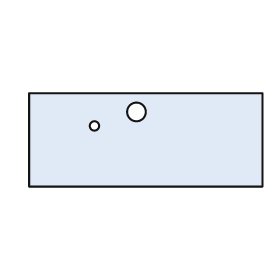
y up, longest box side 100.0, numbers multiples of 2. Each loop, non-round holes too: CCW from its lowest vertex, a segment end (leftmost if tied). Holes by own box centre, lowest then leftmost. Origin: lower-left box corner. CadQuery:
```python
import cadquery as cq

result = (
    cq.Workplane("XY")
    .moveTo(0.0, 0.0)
    .lineTo(100.0, 0.0)
    .lineTo(100.0, 40.0)
    .lineTo(0.0, 40.0)
    .close()
    .moveTo(28.0, 26.0)
    .circle(2.0)
    .moveTo(46.0, 32.0)
    .circle(4.0)
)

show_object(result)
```